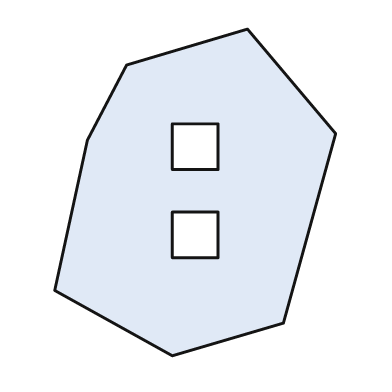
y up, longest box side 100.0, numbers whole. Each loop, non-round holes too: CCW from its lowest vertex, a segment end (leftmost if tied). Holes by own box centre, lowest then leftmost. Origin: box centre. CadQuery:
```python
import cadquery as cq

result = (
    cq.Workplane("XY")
    .moveTo(-7.0, -50.0)
    .lineTo(27.0, -40.0)
    .lineTo(43.0, 18.0)
    .lineTo(16.0, 50.0)
    .lineTo(-21.0, 39.0)
    .lineTo(-33.0, 16.0)
    .lineTo(-43.0, -30.0)
    .close()
    .moveTo(-7.0, -20.0)
    .lineTo(7.0, -20.0)
    .lineTo(7.0, -6.0)
    .lineTo(-7.0, -6.0)
    .close()
    .moveTo(-7.0, 7.0)
    .lineTo(7.0, 7.0)
    .lineTo(7.0, 21.0)
    .lineTo(-7.0, 21.0)
    .close()
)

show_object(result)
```